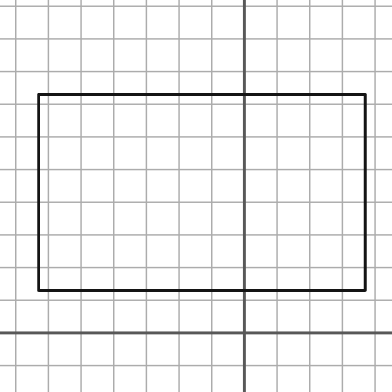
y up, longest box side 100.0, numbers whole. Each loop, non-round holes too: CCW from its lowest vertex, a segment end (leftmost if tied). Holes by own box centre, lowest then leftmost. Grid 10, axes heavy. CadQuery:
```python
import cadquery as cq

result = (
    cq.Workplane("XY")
    .moveTo(-63.0, 13.0)
    .lineTo(37.0, 13.0)
    .lineTo(37.0, 73.0)
    .lineTo(-63.0, 73.0)
    .close()
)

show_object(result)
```